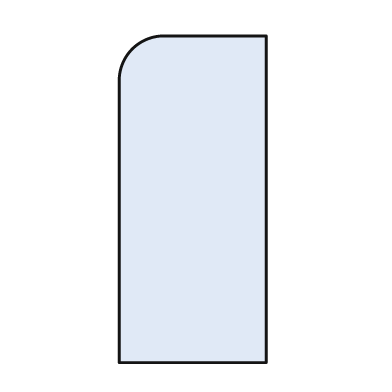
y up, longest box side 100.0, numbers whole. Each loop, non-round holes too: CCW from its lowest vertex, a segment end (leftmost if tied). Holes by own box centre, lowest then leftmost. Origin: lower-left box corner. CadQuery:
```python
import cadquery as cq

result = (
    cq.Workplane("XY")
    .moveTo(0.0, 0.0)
    .lineTo(45.0, 0.0)
    .lineTo(45.0, 100.0)
    .lineTo(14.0, 100.0)
    .threePointArc((4.0, 96.0), (0.0, 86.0))
    .close()
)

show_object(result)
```